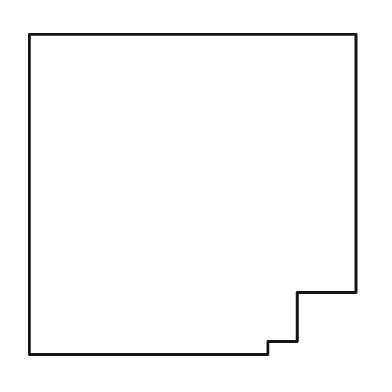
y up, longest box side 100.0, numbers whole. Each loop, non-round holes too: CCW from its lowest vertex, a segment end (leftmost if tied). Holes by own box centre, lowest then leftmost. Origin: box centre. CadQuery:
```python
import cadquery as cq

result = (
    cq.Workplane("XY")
    .moveTo(-50.0, -49.0)
    .lineTo(23.0, -49.0)
    .lineTo(23.0, -45.0)
    .lineTo(32.0, -45.0)
    .lineTo(32.0, -30.0)
    .lineTo(50.0, -30.0)
    .lineTo(50.0, 49.0)
    .lineTo(-50.0, 49.0)
    .close()
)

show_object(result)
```